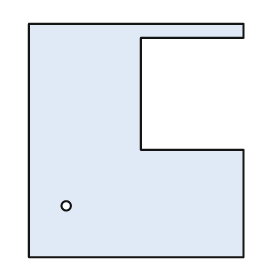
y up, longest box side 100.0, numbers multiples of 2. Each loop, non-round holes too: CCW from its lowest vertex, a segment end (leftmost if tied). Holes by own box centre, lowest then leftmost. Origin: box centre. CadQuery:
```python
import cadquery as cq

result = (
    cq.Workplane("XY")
    .moveTo(-46.0, -50.0)
    .lineTo(46.0, -50.0)
    .lineTo(46.0, -4.0)
    .lineTo(2.0, -4.0)
    .lineTo(2.0, 44.0)
    .lineTo(46.0, 44.0)
    .lineTo(46.0, 50.0)
    .lineTo(-46.0, 50.0)
    .close()
    .moveTo(-30.0, -28.0)
    .circle(2.0)
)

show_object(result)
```